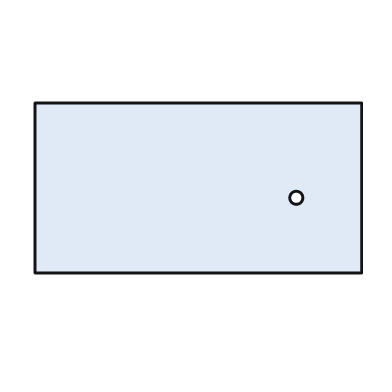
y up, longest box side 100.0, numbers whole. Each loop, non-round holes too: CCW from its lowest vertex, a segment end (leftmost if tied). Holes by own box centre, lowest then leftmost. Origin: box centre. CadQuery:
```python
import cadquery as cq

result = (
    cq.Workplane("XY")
    .moveTo(-50.0, -26.0)
    .lineTo(50.0, -26.0)
    .lineTo(50.0, 26.0)
    .lineTo(-50.0, 26.0)
    .close()
    .moveTo(30.0, -3.0)
    .circle(2.0)
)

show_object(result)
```